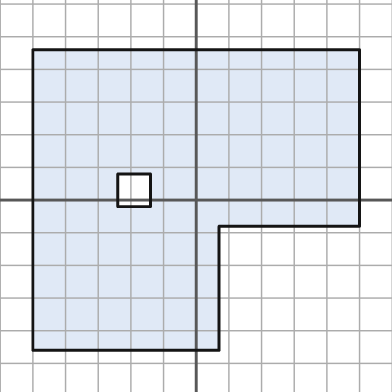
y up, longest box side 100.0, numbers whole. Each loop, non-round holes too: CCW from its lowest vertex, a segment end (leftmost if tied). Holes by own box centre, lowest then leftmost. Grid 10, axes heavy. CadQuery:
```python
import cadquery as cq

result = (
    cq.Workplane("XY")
    .moveTo(-50.0, -46.0)
    .lineTo(7.0, -46.0)
    .lineTo(7.0, -8.0)
    .lineTo(50.0, -8.0)
    .lineTo(50.0, 46.0)
    .lineTo(-50.0, 46.0)
    .close()
    .moveTo(-24.0, -2.0)
    .lineTo(-14.0, -2.0)
    .lineTo(-14.0, 8.0)
    .lineTo(-24.0, 8.0)
    .close()
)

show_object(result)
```